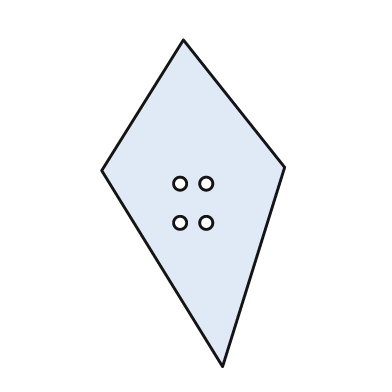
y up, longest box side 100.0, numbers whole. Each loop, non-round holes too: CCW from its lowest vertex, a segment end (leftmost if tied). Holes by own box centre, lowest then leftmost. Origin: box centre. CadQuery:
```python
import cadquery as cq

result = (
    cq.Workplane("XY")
    .moveTo(9.0, -50.0)
    .lineTo(28.0, 11.0)
    .lineTo(-3.0, 50.0)
    .lineTo(-28.0, 10.0)
    .close()
    .moveTo(-4.0, -6.0)
    .circle(2.0)
    .moveTo(4.0, -6.0)
    .circle(2.0)
    .moveTo(-4.0, 6.0)
    .circle(2.0)
    .moveTo(4.0, 6.0)
    .circle(2.0)
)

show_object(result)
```